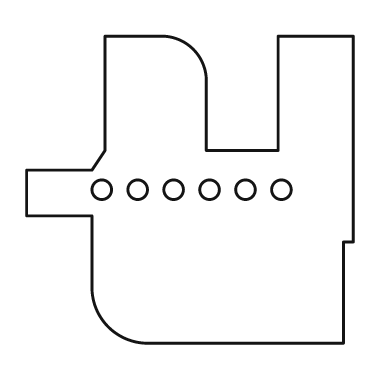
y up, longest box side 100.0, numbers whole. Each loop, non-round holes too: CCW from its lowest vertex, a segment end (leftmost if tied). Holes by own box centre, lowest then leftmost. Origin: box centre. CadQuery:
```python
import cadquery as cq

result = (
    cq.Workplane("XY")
    .moveTo(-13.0, -47.0)
    .lineTo(47.0, -47.0)
    .lineTo(47.0, -16.0)
    .lineTo(50.0, -16.0)
    .lineTo(50.0, 47.0)
    .lineTo(27.0, 47.0)
    .lineTo(27.0, 12.0)
    .lineTo(5.0, 12.0)
    .lineTo(5.0, 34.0)
    .threePointArc((1.0, 43.0), (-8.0, 47.0))
    .lineTo(-26.0, 47.0)
    .lineTo(-26.0, 12.0)
    .lineTo(-30.0, 6.0)
    .lineTo(-50.0, 6.0)
    .lineTo(-50.0, -8.0)
    .lineTo(-30.0, -8.0)
    .lineTo(-30.0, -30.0)
    .threePointArc((-25.0, -42.0), (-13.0, -47.0))
    .close()
    .moveTo(-27.0, 0.0)
    .circle(3.0)
    .moveTo(-16.0, 0.0)
    .circle(3.0)
    .moveTo(-5.0, 0.0)
    .circle(3.0)
    .moveTo(6.0, 0.0)
    .circle(3.0)
    .moveTo(17.0, 0.0)
    .circle(3.0)
    .moveTo(28.0, 0.0)
    .circle(3.0)
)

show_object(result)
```